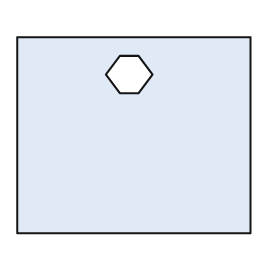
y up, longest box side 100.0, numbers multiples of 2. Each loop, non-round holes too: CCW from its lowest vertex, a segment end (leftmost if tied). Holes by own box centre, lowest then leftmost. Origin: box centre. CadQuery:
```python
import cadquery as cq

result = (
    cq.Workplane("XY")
    .moveTo(-50.0, -42.0)
    .lineTo(50.0, -42.0)
    .lineTo(50.0, 42.0)
    .lineTo(-50.0, 42.0)
    .close()
    .moveTo(-6.0, 18.0)
    .lineTo(2.0, 18.0)
    .lineTo(8.0, 26.0)
    .lineTo(2.0, 34.0)
    .lineTo(-6.0, 34.0)
    .lineTo(-12.0, 26.0)
    .close()
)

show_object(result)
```